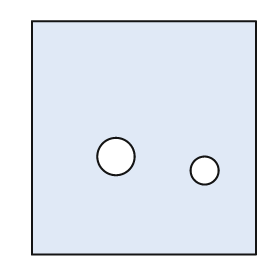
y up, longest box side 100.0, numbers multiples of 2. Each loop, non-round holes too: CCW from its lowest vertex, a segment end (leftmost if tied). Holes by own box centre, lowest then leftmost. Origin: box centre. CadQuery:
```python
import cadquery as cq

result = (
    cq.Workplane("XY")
    .moveTo(-48.0, -50.0)
    .lineTo(48.0, -50.0)
    .lineTo(48.0, 50.0)
    .lineTo(-48.0, 50.0)
    .close()
    .moveTo(26.0, -14.0)
    .circle(6.0)
    .moveTo(-12.0, -8.0)
    .circle(8.0)
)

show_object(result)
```